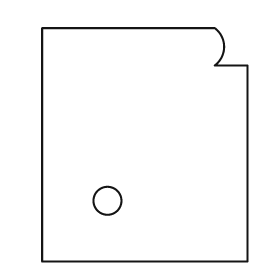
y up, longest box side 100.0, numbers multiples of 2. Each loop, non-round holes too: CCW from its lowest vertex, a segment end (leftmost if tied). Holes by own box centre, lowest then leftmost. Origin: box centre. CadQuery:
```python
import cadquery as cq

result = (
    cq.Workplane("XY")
    .moveTo(-44.0, -50.0)
    .lineTo(44.0, -50.0)
    .lineTo(44.0, 34.0)
    .lineTo(30.0, 34.0)
    .threePointArc((34.0, 42.0), (30.0, 50.0))
    .lineTo(-44.0, 50.0)
    .close()
    .moveTo(-16.0, -24.0)
    .circle(6.0)
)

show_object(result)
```